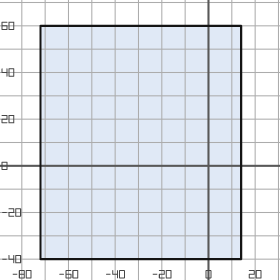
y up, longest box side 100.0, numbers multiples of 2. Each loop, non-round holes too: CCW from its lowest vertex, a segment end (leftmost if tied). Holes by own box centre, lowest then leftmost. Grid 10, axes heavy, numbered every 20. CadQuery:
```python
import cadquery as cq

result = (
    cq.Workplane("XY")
    .moveTo(-72.0, -40.0)
    .lineTo(14.0, -40.0)
    .lineTo(14.0, 60.0)
    .lineTo(-72.0, 60.0)
    .close()
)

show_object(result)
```